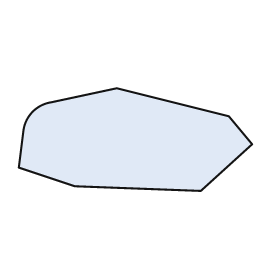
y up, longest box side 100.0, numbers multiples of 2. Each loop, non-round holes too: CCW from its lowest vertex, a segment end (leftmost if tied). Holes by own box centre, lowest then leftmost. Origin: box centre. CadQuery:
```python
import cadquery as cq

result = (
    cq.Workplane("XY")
    .moveTo(28.0, -22.0)
    .lineTo(50.0, -2.0)
    .lineTo(40.0, 10.0)
    .lineTo(-8.0, 22.0)
    .lineTo(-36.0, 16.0)
    .threePointArc((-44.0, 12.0), (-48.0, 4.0))
    .lineTo(-50.0, -12.0)
    .lineTo(-26.0, -20.0)
    .close()
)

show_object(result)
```